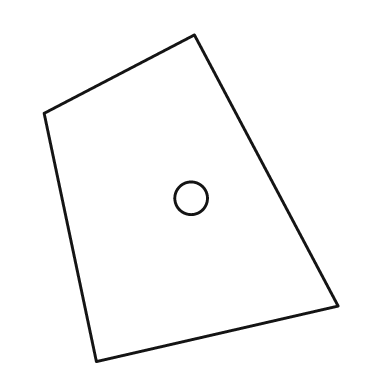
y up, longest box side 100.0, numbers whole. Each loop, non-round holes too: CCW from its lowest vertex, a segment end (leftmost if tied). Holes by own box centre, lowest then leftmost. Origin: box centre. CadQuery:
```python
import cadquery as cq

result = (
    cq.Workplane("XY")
    .moveTo(-29.0, -50.0)
    .lineTo(45.0, -33.0)
    .lineTo(1.0, 50.0)
    .lineTo(-45.0, 26.0)
    .close()
    .moveTo(0.0, 0.0)
    .circle(5.0)
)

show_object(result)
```